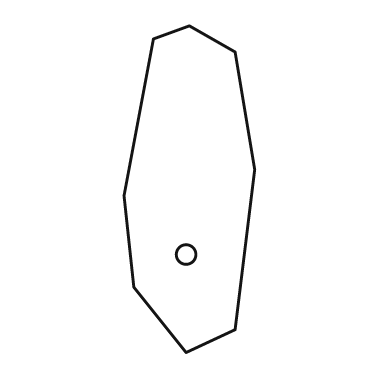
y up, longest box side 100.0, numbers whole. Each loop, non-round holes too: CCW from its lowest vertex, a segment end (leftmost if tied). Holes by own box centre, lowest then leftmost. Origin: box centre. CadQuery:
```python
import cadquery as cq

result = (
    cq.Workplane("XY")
    .moveTo(-1.0, -50.0)
    .lineTo(14.0, -43.0)
    .lineTo(20.0, 6.0)
    .lineTo(14.0, 42.0)
    .lineTo(0.0, 50.0)
    .lineTo(-11.0, 46.0)
    .lineTo(-20.0, -2.0)
    .lineTo(-17.0, -30.0)
    .close()
    .moveTo(-1.0, -20.0)
    .circle(3.0)
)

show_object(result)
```